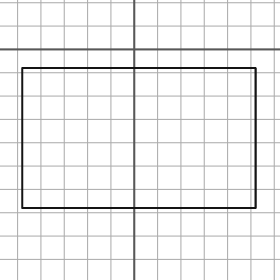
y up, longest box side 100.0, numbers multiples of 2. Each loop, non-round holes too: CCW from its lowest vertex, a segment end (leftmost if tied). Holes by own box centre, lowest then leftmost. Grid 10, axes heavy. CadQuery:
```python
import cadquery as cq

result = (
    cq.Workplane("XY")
    .moveTo(-48.0, -68.0)
    .lineTo(52.0, -68.0)
    .lineTo(52.0, -8.0)
    .lineTo(-48.0, -8.0)
    .close()
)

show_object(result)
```